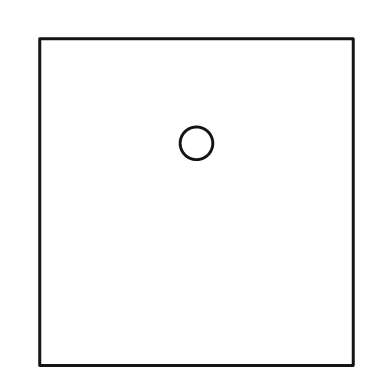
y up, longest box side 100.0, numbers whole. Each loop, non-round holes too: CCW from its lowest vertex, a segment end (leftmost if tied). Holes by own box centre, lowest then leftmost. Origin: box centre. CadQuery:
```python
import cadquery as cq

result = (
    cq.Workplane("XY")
    .moveTo(-48.0, -50.0)
    .lineTo(48.0, -50.0)
    .lineTo(48.0, 50.0)
    .lineTo(-48.0, 50.0)
    .close()
    .moveTo(0.0, 18.0)
    .circle(5.0)
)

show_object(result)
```